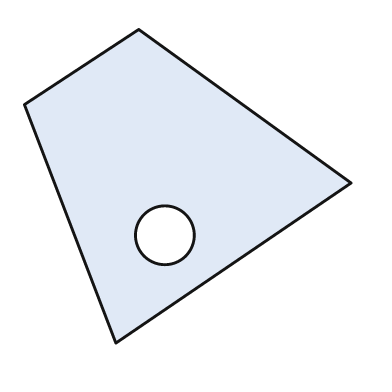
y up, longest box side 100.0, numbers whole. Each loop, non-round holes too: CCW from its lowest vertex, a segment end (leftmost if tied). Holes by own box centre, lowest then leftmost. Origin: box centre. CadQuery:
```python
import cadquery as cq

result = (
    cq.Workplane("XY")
    .moveTo(-22.0, -48.0)
    .lineTo(50.0, 1.0)
    .lineTo(-15.0, 48.0)
    .lineTo(-50.0, 25.0)
    .close()
    .moveTo(-7.0, -15.0)
    .circle(9.0)
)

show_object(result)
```